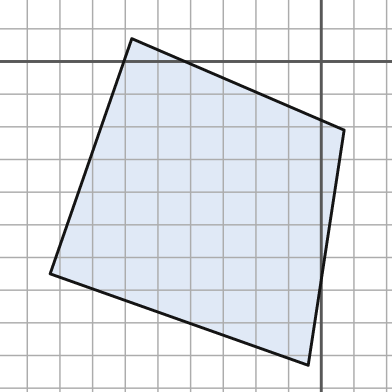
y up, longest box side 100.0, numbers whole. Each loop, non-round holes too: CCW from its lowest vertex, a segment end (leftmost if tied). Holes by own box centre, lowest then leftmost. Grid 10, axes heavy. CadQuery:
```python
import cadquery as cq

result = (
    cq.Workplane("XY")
    .moveTo(-4.0, -93.0)
    .lineTo(7.0, -21.0)
    .lineTo(-58.0, 7.0)
    .lineTo(-83.0, -65.0)
    .close()
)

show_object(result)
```